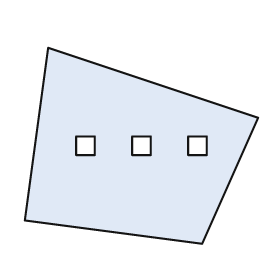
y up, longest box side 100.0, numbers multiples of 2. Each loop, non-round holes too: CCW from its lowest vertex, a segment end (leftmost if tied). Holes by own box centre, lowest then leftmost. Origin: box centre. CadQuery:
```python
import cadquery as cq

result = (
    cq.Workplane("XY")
    .moveTo(26.0, -42.0)
    .lineTo(50.0, 12.0)
    .lineTo(-40.0, 42.0)
    .lineTo(-50.0, -32.0)
    .close()
    .moveTo(-28.0, -4.0)
    .lineTo(-20.0, -4.0)
    .lineTo(-20.0, 4.0)
    .lineTo(-28.0, 4.0)
    .close()
    .moveTo(-4.0, -4.0)
    .lineTo(4.0, -4.0)
    .lineTo(4.0, 4.0)
    .lineTo(-4.0, 4.0)
    .close()
    .moveTo(20.0, -4.0)
    .lineTo(28.0, -4.0)
    .lineTo(28.0, 4.0)
    .lineTo(20.0, 4.0)
    .close()
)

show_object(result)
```